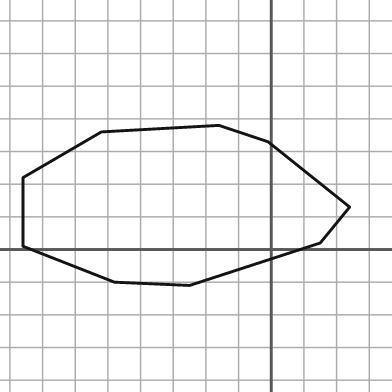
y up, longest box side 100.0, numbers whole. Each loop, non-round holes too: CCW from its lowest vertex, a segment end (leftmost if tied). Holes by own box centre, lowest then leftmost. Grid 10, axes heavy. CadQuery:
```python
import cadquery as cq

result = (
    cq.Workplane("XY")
    .moveTo(-25.0, -11.0)
    .lineTo(15.0, 2.0)
    .lineTo(24.0, 13.0)
    .lineTo(-1.0, 33.0)
    .lineTo(-16.0, 38.0)
    .lineTo(-52.0, 36.0)
    .lineTo(-76.0, 22.0)
    .lineTo(-76.0, 1.0)
    .lineTo(-48.0, -10.0)
    .close()
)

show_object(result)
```